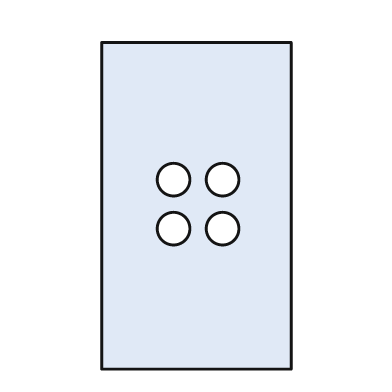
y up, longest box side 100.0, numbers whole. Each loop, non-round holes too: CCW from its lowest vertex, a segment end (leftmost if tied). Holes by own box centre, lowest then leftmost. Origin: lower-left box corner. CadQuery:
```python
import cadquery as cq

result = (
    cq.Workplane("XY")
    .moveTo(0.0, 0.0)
    .lineTo(58.0, 0.0)
    .lineTo(58.0, 100.0)
    .lineTo(0.0, 100.0)
    .close()
    .moveTo(22.0, 43.0)
    .circle(5.0)
    .moveTo(37.0, 43.0)
    .circle(5.0)
    .moveTo(22.0, 58.0)
    .circle(5.0)
    .moveTo(37.0, 58.0)
    .circle(5.0)
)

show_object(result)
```